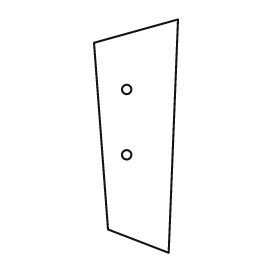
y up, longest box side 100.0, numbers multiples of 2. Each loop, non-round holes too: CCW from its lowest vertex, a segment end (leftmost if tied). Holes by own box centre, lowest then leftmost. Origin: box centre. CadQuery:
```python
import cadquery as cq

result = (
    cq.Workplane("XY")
    .moveTo(14.0, -50.0)
    .lineTo(18.0, 50.0)
    .lineTo(-18.0, 40.0)
    .lineTo(-12.0, -40.0)
    .close()
    .moveTo(-4.0, -8.0)
    .circle(2.0)
    .moveTo(-4.0, 20.0)
    .circle(2.0)
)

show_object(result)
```